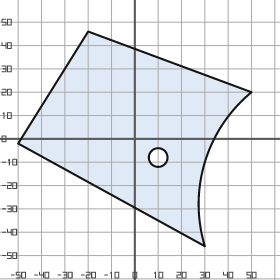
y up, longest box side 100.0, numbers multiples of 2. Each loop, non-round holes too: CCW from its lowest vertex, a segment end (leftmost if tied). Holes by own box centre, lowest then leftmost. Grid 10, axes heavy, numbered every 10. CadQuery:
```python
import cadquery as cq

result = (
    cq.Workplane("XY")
    .moveTo(30.0, -46.0)
    .threePointArc((30.0, -10.0), (50.0, 20.0))
    .lineTo(-20.0, 46.0)
    .lineTo(-50.0, -2.0)
    .close()
    .moveTo(10.0, -8.0)
    .circle(4.0)
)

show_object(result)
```